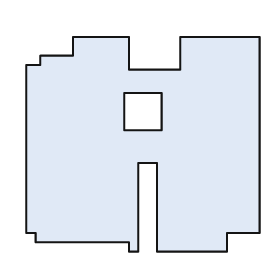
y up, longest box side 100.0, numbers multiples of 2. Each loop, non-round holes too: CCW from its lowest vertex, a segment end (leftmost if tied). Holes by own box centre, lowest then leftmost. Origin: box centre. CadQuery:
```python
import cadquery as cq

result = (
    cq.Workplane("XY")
    .moveTo(-6.0, -46.0)
    .lineTo(-2.0, -46.0)
    .lineTo(-2.0, -8.0)
    .lineTo(6.0, -8.0)
    .lineTo(6.0, -46.0)
    .lineTo(36.0, -46.0)
    .lineTo(36.0, -38.0)
    .lineTo(50.0, -38.0)
    .lineTo(50.0, 46.0)
    .lineTo(16.0, 46.0)
    .lineTo(16.0, 32.0)
    .lineTo(-6.0, 32.0)
    .lineTo(-6.0, 46.0)
    .lineTo(-30.0, 46.0)
    .lineTo(-30.0, 38.0)
    .lineTo(-44.0, 38.0)
    .lineTo(-44.0, 34.0)
    .lineTo(-50.0, 34.0)
    .lineTo(-50.0, -38.0)
    .lineTo(-46.0, -38.0)
    .lineTo(-46.0, -42.0)
    .lineTo(-6.0, -42.0)
    .close()
    .moveTo(-8.0, 6.0)
    .lineTo(8.0, 6.0)
    .lineTo(8.0, 22.0)
    .lineTo(-8.0, 22.0)
    .close()
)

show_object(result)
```